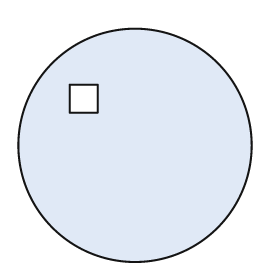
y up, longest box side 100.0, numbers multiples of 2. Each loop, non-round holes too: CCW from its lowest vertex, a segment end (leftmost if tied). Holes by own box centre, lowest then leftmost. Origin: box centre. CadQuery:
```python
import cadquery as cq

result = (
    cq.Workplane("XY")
    .moveTo(0.0, 0.0)
    .circle(50.0)
    .moveTo(-28.0, 14.0)
    .lineTo(-16.0, 14.0)
    .lineTo(-16.0, 26.0)
    .lineTo(-28.0, 26.0)
    .close()
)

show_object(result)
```